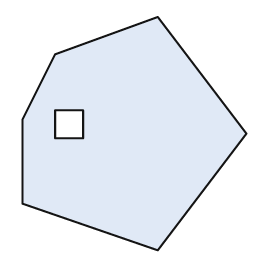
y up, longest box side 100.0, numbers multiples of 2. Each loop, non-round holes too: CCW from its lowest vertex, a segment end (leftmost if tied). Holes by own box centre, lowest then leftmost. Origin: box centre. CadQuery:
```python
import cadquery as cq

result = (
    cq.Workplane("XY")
    .moveTo(10.0, -50.0)
    .lineTo(48.0, 0.0)
    .lineTo(10.0, 50.0)
    .lineTo(-34.0, 34.0)
    .lineTo(-48.0, 6.0)
    .lineTo(-48.0, -30.0)
    .close()
    .moveTo(-34.0, -2.0)
    .lineTo(-22.0, -2.0)
    .lineTo(-22.0, 10.0)
    .lineTo(-34.0, 10.0)
    .close()
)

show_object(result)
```